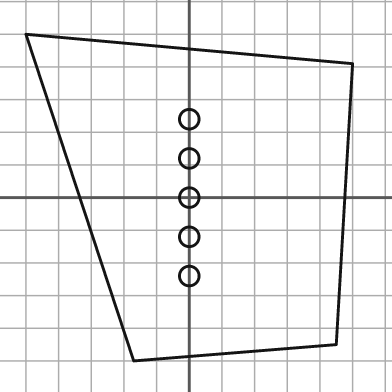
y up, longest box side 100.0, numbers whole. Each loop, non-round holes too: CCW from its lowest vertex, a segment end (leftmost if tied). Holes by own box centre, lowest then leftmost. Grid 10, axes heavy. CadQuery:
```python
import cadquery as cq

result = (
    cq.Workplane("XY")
    .moveTo(-17.0, -50.0)
    .lineTo(45.0, -45.0)
    .lineTo(50.0, 41.0)
    .lineTo(-50.0, 50.0)
    .close()
    .moveTo(0.0, -24.0)
    .circle(3.0)
    .moveTo(0.0, -12.0)
    .circle(3.0)
    .moveTo(0.0, 0.0)
    .circle(3.0)
    .moveTo(0.0, 12.0)
    .circle(3.0)
    .moveTo(0.0, 24.0)
    .circle(3.0)
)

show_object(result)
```